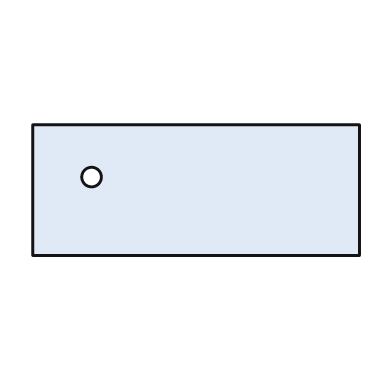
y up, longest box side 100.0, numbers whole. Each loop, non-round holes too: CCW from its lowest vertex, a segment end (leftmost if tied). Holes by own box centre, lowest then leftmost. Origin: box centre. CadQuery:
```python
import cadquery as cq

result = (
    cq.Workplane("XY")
    .moveTo(-50.0, -20.0)
    .lineTo(50.0, -20.0)
    .lineTo(50.0, 20.0)
    .lineTo(-50.0, 20.0)
    .close()
    .moveTo(-32.0, 4.0)
    .circle(3.0)
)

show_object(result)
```